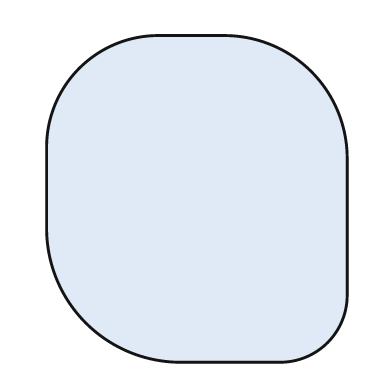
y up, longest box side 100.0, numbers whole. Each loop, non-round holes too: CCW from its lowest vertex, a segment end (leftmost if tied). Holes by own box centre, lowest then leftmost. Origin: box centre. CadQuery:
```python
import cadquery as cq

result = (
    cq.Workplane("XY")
    .moveTo(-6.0, -50.0)
    .lineTo(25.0, -50.0)
    .threePointArc((40.0, -44.0), (46.0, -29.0))
    .lineTo(46.0, 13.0)
    .threePointArc((35.0, 39.0), (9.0, 50.0))
    .lineTo(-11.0, 50.0)
    .threePointArc((-36.0, 40.0), (-46.0, 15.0))
    .lineTo(-46.0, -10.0)
    .threePointArc((-34.0, -38.0), (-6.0, -50.0))
    .close()
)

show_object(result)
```